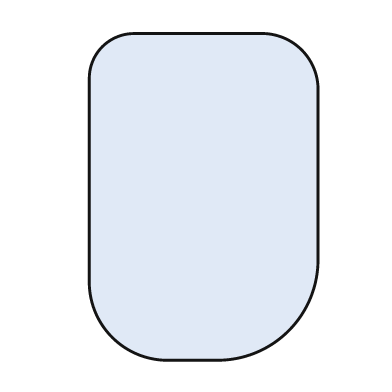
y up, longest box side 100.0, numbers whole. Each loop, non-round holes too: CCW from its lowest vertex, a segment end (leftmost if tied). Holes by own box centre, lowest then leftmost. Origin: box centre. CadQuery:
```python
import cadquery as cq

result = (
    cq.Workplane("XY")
    .moveTo(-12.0, -50.0)
    .lineTo(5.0, -50.0)
    .threePointArc((26.0, -41.0), (35.0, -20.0))
    .lineTo(35.0, 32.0)
    .threePointArc((30.0, 45.0), (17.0, 50.0))
    .lineTo(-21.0, 50.0)
    .threePointArc((-31.0, 46.0), (-35.0, 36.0))
    .lineTo(-35.0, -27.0)
    .threePointArc((-28.0, -43.0), (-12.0, -50.0))
    .close()
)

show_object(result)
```